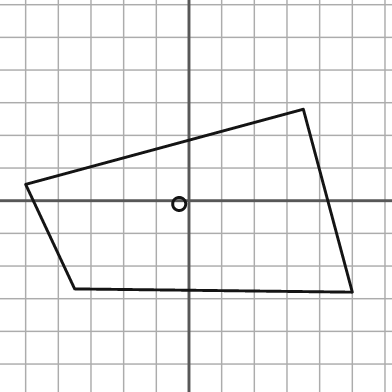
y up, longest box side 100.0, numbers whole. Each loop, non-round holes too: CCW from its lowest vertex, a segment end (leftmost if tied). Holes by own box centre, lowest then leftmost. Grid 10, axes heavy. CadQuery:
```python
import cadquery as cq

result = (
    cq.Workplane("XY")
    .moveTo(50.0, -28.0)
    .lineTo(35.0, 28.0)
    .lineTo(-50.0, 5.0)
    .lineTo(-35.0, -27.0)
    .close()
    .moveTo(-3.0, -1.0)
    .circle(2.0)
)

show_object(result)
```